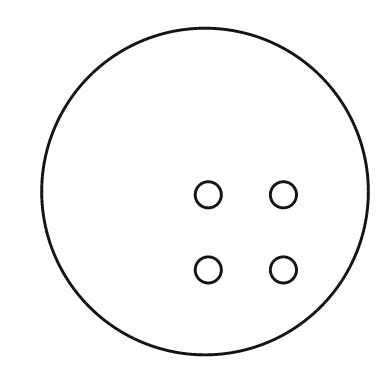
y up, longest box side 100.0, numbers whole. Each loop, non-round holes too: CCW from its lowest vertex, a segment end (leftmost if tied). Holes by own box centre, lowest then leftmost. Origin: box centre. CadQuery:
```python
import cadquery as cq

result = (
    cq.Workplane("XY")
    .moveTo(0.0, 0.0)
    .circle(50.0)
    .moveTo(1.0, -24.0)
    .circle(4.0)
    .moveTo(24.0, -24.0)
    .circle(4.0)
    .moveTo(1.0, -1.0)
    .circle(4.0)
    .moveTo(24.0, -1.0)
    .circle(4.0)
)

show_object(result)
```